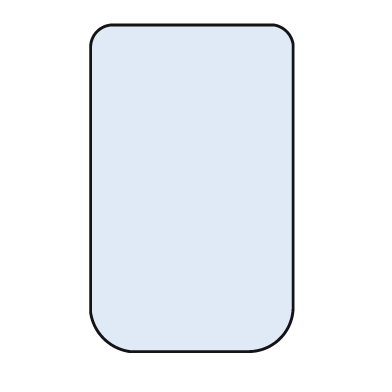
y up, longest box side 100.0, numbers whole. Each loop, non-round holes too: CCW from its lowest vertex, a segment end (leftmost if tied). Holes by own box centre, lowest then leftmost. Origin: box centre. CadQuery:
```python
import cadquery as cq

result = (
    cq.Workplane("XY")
    .moveTo(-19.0, -50.0)
    .lineTo(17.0, -50.0)
    .threePointArc((27.0, -46.0), (31.0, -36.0))
    .lineTo(31.0, 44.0)
    .threePointArc((29.0, 48.0), (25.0, 50.0))
    .lineTo(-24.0, 50.0)
    .threePointArc((-29.0, 48.0), (-31.0, 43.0))
    .lineTo(-31.0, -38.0)
    .threePointArc((-27.0, -46.0), (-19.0, -50.0))
    .close()
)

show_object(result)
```